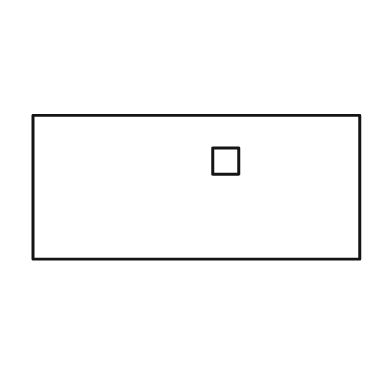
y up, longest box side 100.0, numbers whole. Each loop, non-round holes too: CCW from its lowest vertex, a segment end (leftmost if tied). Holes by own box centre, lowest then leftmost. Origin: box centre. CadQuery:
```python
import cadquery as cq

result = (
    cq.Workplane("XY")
    .moveTo(-50.0, -22.0)
    .lineTo(50.0, -22.0)
    .lineTo(50.0, 22.0)
    .lineTo(-50.0, 22.0)
    .close()
    .moveTo(5.0, 4.0)
    .lineTo(13.0, 4.0)
    .lineTo(13.0, 12.0)
    .lineTo(5.0, 12.0)
    .close()
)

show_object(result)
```